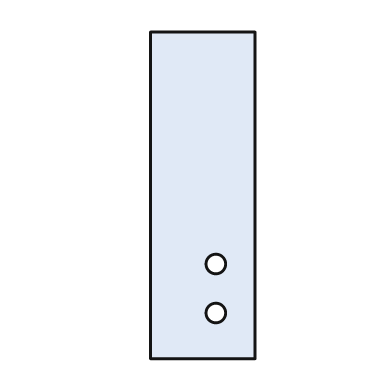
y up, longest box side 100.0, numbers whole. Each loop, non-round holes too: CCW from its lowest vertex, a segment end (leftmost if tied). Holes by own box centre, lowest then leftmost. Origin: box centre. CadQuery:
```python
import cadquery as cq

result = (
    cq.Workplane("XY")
    .moveTo(-16.0, -50.0)
    .lineTo(16.0, -50.0)
    .lineTo(16.0, 50.0)
    .lineTo(-16.0, 50.0)
    .close()
    .moveTo(4.0, -36.0)
    .circle(3.0)
    .moveTo(4.0, -21.0)
    .circle(3.0)
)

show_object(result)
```